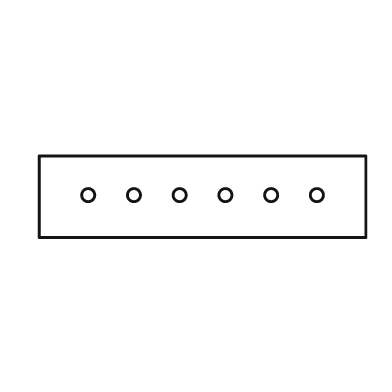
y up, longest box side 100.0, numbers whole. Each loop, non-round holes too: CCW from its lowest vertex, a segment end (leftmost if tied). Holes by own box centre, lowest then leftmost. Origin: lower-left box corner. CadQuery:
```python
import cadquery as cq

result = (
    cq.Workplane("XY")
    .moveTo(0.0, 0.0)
    .lineTo(100.0, 0.0)
    .lineTo(100.0, 25.0)
    .lineTo(0.0, 25.0)
    .close()
    .moveTo(15.0, 13.0)
    .circle(2.0)
    .moveTo(29.0, 13.0)
    .circle(2.0)
    .moveTo(43.0, 13.0)
    .circle(2.0)
    .moveTo(57.0, 13.0)
    .circle(2.0)
    .moveTo(71.0, 13.0)
    .circle(2.0)
    .moveTo(85.0, 13.0)
    .circle(2.0)
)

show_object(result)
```